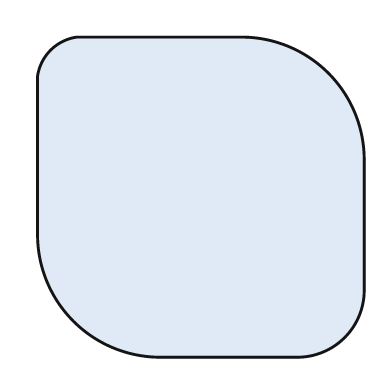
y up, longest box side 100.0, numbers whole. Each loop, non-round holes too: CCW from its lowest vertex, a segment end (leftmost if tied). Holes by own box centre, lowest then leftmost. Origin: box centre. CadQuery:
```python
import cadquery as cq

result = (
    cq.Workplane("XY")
    .moveTo(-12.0, -49.0)
    .lineTo(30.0, -49.0)
    .threePointArc((44.0, -43.0), (50.0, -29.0))
    .lineTo(50.0, 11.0)
    .threePointArc((39.0, 38.0), (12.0, 49.0))
    .lineTo(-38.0, 49.0)
    .threePointArc((-46.0, 45.0), (-50.0, 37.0))
    .lineTo(-50.0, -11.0)
    .threePointArc((-39.0, -38.0), (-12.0, -49.0))
    .close()
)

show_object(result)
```